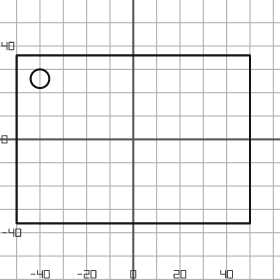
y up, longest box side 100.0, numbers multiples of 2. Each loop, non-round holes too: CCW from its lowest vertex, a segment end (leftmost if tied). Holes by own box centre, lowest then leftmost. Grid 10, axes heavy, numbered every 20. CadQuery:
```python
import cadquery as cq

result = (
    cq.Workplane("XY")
    .moveTo(-50.0, -36.0)
    .lineTo(50.0, -36.0)
    .lineTo(50.0, 36.0)
    .lineTo(-50.0, 36.0)
    .close()
    .moveTo(-40.0, 26.0)
    .circle(4.0)
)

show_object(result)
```